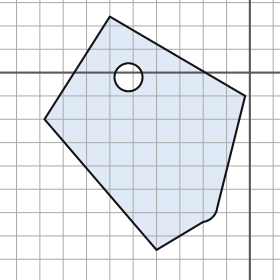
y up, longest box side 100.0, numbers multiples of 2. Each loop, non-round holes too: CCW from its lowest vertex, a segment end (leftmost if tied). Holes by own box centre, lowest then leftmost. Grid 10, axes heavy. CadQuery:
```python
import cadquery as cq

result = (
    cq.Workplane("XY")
    .moveTo(-40.0, -76.0)
    .lineTo(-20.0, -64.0)
    .threePointArc((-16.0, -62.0), (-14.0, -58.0))
    .lineTo(-2.0, -10.0)
    .lineTo(-60.0, 24.0)
    .lineTo(-88.0, -20.0)
    .close()
    .moveTo(-52.0, -2.0)
    .circle(6.0)
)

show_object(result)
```